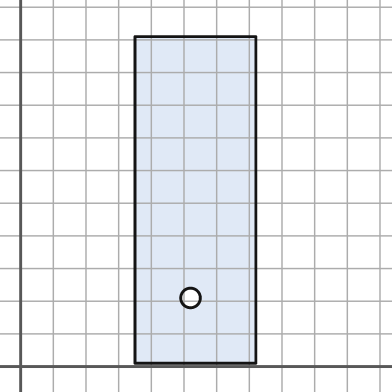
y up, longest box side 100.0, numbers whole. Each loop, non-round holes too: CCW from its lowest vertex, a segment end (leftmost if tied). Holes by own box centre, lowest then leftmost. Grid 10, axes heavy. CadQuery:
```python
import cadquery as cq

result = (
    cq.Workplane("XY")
    .moveTo(35.0, 1.0)
    .lineTo(72.0, 1.0)
    .lineTo(72.0, 101.0)
    .lineTo(35.0, 101.0)
    .close()
    .moveTo(52.0, 21.0)
    .circle(3.0)
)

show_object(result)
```